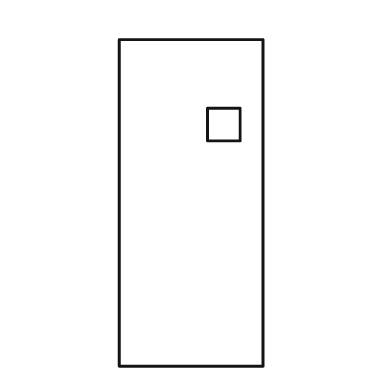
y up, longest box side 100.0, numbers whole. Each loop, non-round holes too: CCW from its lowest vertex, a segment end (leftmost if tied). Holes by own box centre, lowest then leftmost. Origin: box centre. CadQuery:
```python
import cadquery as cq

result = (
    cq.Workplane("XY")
    .moveTo(-22.0, -50.0)
    .lineTo(22.0, -50.0)
    .lineTo(22.0, 50.0)
    .lineTo(-22.0, 50.0)
    .close()
    .moveTo(5.0, 19.0)
    .lineTo(15.0, 19.0)
    .lineTo(15.0, 29.0)
    .lineTo(5.0, 29.0)
    .close()
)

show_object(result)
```